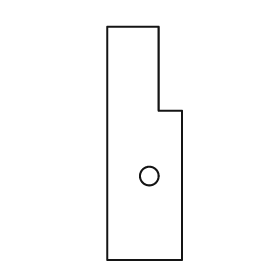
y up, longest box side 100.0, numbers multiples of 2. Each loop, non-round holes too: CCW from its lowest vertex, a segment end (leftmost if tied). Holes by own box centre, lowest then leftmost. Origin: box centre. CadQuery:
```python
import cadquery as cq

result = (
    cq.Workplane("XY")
    .moveTo(-16.0, -50.0)
    .lineTo(16.0, -50.0)
    .lineTo(16.0, 14.0)
    .lineTo(6.0, 14.0)
    .lineTo(6.0, 50.0)
    .lineTo(-16.0, 50.0)
    .close()
    .moveTo(2.0, -14.0)
    .circle(4.0)
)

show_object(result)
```